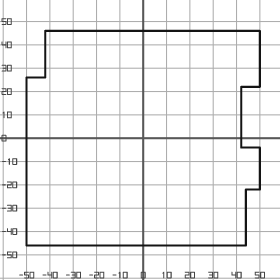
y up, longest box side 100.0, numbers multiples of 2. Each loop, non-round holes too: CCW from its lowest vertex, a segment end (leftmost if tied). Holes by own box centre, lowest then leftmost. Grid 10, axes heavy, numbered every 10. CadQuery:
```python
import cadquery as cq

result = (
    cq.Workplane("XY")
    .moveTo(-50.0, -46.0)
    .lineTo(44.0, -46.0)
    .lineTo(44.0, -22.0)
    .lineTo(50.0, -22.0)
    .lineTo(50.0, -4.0)
    .lineTo(42.0, -4.0)
    .lineTo(42.0, 22.0)
    .lineTo(50.0, 22.0)
    .lineTo(50.0, 46.0)
    .lineTo(-42.0, 46.0)
    .lineTo(-42.0, 26.0)
    .lineTo(-50.0, 26.0)
    .close()
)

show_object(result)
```